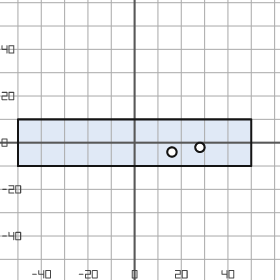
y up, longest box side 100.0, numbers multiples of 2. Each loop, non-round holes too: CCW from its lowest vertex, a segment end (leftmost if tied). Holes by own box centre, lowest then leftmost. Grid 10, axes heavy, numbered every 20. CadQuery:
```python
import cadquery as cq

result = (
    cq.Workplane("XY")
    .moveTo(-50.0, -10.0)
    .lineTo(50.0, -10.0)
    .lineTo(50.0, 10.0)
    .lineTo(-50.0, 10.0)
    .close()
    .moveTo(16.0, -4.0)
    .circle(2.0)
    .moveTo(28.0, -2.0)
    .circle(2.0)
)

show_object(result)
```